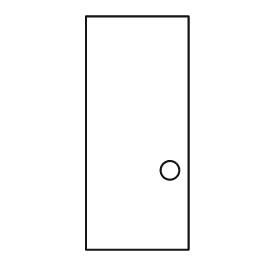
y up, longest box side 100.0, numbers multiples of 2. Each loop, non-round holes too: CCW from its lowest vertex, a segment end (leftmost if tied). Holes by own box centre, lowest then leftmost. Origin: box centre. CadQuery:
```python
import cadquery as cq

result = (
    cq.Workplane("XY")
    .moveTo(-22.0, -50.0)
    .lineTo(22.0, -50.0)
    .lineTo(22.0, 50.0)
    .lineTo(-22.0, 50.0)
    .close()
    .moveTo(14.0, -16.0)
    .circle(4.0)
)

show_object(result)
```